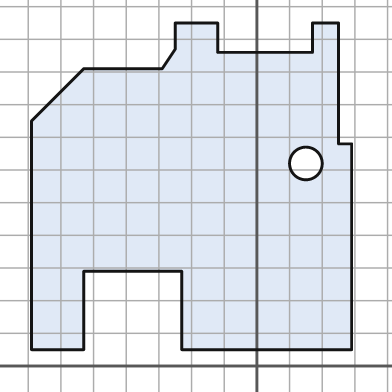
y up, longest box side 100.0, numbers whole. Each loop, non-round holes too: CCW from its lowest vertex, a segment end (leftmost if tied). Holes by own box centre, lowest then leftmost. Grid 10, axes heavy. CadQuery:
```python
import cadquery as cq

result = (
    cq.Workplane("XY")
    .moveTo(-69.0, 5.0)
    .lineTo(-53.0, 5.0)
    .lineTo(-53.0, 29.0)
    .lineTo(-23.0, 29.0)
    .lineTo(-23.0, 5.0)
    .lineTo(29.0, 5.0)
    .lineTo(29.0, 68.0)
    .lineTo(25.0, 68.0)
    .lineTo(25.0, 105.0)
    .lineTo(17.0, 105.0)
    .lineTo(17.0, 96.0)
    .lineTo(-12.0, 96.0)
    .lineTo(-12.0, 105.0)
    .lineTo(-25.0, 105.0)
    .lineTo(-25.0, 97.0)
    .lineTo(-29.0, 91.0)
    .lineTo(-53.0, 91.0)
    .lineTo(-69.0, 75.0)
    .close()
    .moveTo(15.0, 62.0)
    .circle(5.0)
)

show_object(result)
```